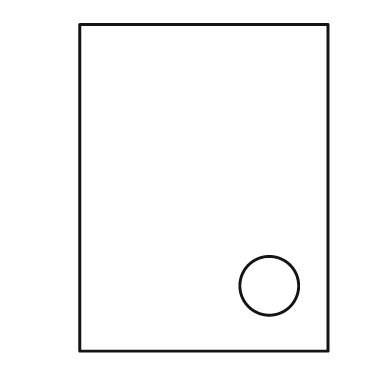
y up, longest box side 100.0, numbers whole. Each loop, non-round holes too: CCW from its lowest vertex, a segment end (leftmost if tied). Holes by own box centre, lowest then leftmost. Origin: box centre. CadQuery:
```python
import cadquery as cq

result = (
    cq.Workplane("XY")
    .moveTo(-38.0, -50.0)
    .lineTo(38.0, -50.0)
    .lineTo(38.0, 50.0)
    .lineTo(-38.0, 50.0)
    .close()
    .moveTo(20.0, -30.0)
    .circle(9.0)
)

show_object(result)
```